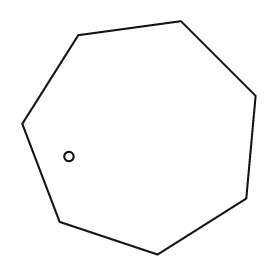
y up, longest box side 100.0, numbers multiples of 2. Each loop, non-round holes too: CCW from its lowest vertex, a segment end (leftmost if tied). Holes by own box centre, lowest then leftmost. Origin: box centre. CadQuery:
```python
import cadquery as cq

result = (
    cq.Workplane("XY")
    .moveTo(8.0, -50.0)
    .lineTo(46.0, -26.0)
    .lineTo(50.0, 18.0)
    .lineTo(18.0, 50.0)
    .lineTo(-26.0, 44.0)
    .lineTo(-50.0, 6.0)
    .lineTo(-34.0, -36.0)
    .close()
    .moveTo(-30.0, -8.0)
    .circle(2.0)
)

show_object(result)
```